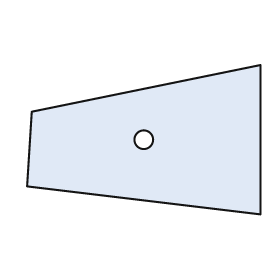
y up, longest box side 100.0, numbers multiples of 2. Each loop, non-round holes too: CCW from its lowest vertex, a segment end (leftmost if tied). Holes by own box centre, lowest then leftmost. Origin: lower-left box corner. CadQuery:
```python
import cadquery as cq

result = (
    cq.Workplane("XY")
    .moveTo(100.0, 0.0)
    .lineTo(100.0, 64.0)
    .lineTo(2.0, 44.0)
    .lineTo(0.0, 12.0)
    .close()
    .moveTo(50.0, 32.0)
    .circle(4.0)
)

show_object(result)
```